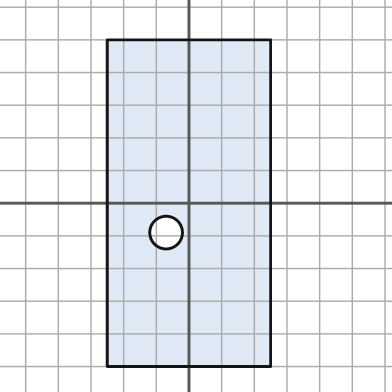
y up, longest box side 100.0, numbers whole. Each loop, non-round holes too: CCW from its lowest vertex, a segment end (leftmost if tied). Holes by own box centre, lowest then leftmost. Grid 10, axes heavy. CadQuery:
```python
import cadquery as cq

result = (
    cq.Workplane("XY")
    .moveTo(-25.0, -50.0)
    .lineTo(25.0, -50.0)
    .lineTo(25.0, 50.0)
    .lineTo(-25.0, 50.0)
    .close()
    .moveTo(-7.0, -9.0)
    .circle(5.0)
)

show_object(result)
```